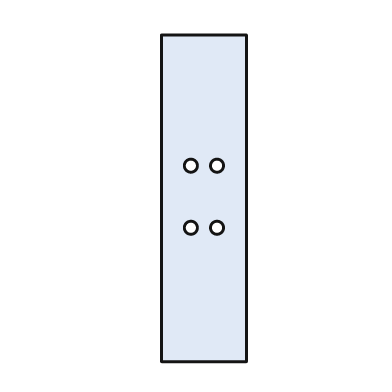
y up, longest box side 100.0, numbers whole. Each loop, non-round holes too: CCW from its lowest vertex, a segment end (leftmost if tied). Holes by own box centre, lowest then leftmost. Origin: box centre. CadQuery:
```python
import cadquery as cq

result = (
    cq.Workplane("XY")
    .moveTo(-13.0, -50.0)
    .lineTo(13.0, -50.0)
    .lineTo(13.0, 50.0)
    .lineTo(-13.0, 50.0)
    .close()
    .moveTo(-4.0, -9.0)
    .circle(2.0)
    .moveTo(4.0, -9.0)
    .circle(2.0)
    .moveTo(-4.0, 10.0)
    .circle(2.0)
    .moveTo(4.0, 10.0)
    .circle(2.0)
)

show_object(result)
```